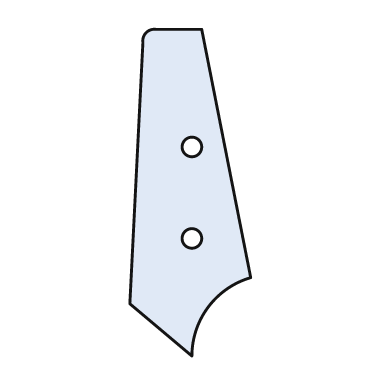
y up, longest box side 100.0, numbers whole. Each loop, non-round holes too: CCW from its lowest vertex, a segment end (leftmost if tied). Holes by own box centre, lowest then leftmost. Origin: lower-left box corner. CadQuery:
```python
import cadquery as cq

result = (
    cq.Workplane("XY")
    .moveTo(19.0, 0.0)
    .threePointArc((24.0, 15.0), (37.0, 24.0))
    .lineTo(22.0, 100.0)
    .lineTo(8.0, 100.0)
    .threePointArc((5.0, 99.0), (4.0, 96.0))
    .lineTo(0.0, 16.0)
    .close()
    .moveTo(19.0, 36.0)
    .circle(3.0)
    .moveTo(19.0, 64.0)
    .circle(3.0)
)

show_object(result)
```